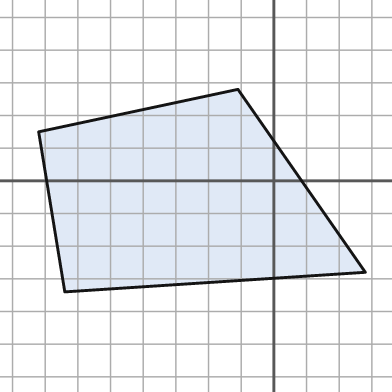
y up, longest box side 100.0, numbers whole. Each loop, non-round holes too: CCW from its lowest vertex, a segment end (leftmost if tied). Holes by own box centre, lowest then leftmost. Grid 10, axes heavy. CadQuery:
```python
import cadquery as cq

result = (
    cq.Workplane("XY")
    .moveTo(-64.0, -34.0)
    .lineTo(28.0, -28.0)
    .lineTo(-11.0, 28.0)
    .lineTo(-72.0, 15.0)
    .close()
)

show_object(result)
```